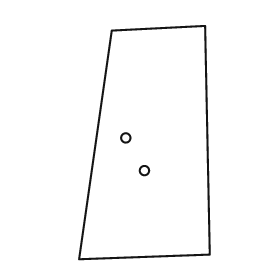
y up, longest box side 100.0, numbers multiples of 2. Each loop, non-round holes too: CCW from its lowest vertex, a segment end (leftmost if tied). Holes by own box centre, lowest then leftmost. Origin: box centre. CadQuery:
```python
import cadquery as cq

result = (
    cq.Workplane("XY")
    .moveTo(-28.0, -50.0)
    .lineTo(28.0, -48.0)
    .lineTo(26.0, 50.0)
    .lineTo(-14.0, 48.0)
    .close()
    .moveTo(0.0, -12.0)
    .circle(2.0)
    .moveTo(-8.0, 2.0)
    .circle(2.0)
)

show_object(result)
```